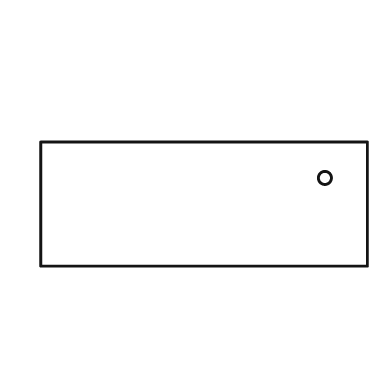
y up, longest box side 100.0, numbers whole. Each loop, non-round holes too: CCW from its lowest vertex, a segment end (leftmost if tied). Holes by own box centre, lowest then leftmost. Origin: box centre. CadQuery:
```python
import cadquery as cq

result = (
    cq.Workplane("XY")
    .moveTo(-50.0, -19.0)
    .lineTo(50.0, -19.0)
    .lineTo(50.0, 19.0)
    .lineTo(-50.0, 19.0)
    .close()
    .moveTo(37.0, 8.0)
    .circle(2.0)
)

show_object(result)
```